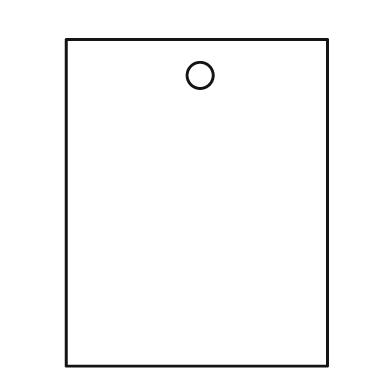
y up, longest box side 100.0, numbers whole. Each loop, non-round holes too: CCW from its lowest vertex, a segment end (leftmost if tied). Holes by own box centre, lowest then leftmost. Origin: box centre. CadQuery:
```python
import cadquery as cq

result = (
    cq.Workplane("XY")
    .moveTo(-40.0, -50.0)
    .lineTo(40.0, -50.0)
    .lineTo(40.0, 50.0)
    .lineTo(-40.0, 50.0)
    .close()
    .moveTo(1.0, 39.0)
    .circle(4.0)
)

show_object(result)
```